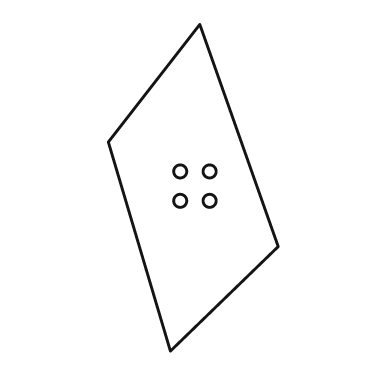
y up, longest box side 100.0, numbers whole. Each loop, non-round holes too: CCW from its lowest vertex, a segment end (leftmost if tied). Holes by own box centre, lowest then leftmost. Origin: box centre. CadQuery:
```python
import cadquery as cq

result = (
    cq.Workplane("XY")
    .moveTo(-7.0, -50.0)
    .lineTo(26.0, -18.0)
    .lineTo(2.0, 50.0)
    .lineTo(-26.0, 14.0)
    .close()
    .moveTo(-4.0, -4.0)
    .circle(2.0)
    .moveTo(5.0, -4.0)
    .circle(2.0)
    .moveTo(-4.0, 5.0)
    .circle(2.0)
    .moveTo(5.0, 5.0)
    .circle(2.0)
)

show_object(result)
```